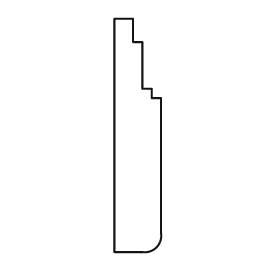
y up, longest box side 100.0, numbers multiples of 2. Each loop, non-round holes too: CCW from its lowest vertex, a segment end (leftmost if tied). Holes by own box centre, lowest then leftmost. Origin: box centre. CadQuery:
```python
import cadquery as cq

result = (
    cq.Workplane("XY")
    .moveTo(-10.0, -50.0)
    .lineTo(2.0, -50.0)
    .threePointArc((8.0, -48.0), (10.0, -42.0))
    .lineTo(10.0, 16.0)
    .lineTo(6.0, 16.0)
    .lineTo(6.0, 20.0)
    .lineTo(2.0, 20.0)
    .lineTo(2.0, 40.0)
    .lineTo(-2.0, 40.0)
    .lineTo(-2.0, 50.0)
    .lineTo(-10.0, 50.0)
    .close()
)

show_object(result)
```